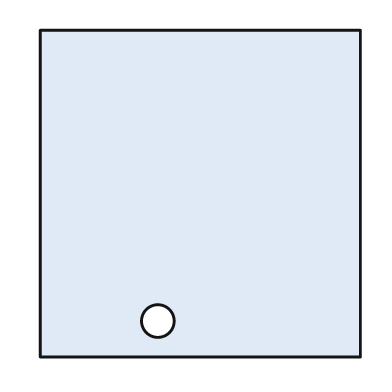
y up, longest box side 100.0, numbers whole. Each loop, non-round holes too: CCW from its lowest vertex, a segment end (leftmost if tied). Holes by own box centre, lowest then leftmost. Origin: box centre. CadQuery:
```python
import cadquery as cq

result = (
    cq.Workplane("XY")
    .moveTo(-49.0, -50.0)
    .lineTo(49.0, -50.0)
    .lineTo(49.0, 50.0)
    .lineTo(-49.0, 50.0)
    .close()
    .moveTo(-13.0, -39.0)
    .circle(5.0)
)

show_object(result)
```